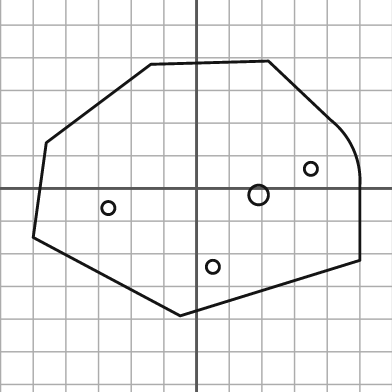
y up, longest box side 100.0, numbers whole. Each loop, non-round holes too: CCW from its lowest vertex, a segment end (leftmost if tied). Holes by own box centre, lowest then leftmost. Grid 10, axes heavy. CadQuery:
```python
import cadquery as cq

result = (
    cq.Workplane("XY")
    .moveTo(-5.0, -39.0)
    .lineTo(50.0, -22.0)
    .lineTo(50.0, 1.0)
    .threePointArc((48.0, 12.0), (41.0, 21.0))
    .lineTo(22.0, 39.0)
    .lineTo(-14.0, 38.0)
    .lineTo(-46.0, 14.0)
    .lineTo(-50.0, -15.0)
    .close()
    .moveTo(5.0, -24.0)
    .circle(2.0)
    .moveTo(-27.0, -6.0)
    .circle(2.0)
    .moveTo(19.0, -2.0)
    .circle(3.0)
    .moveTo(35.0, 6.0)
    .circle(2.0)
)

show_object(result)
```